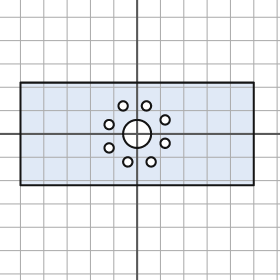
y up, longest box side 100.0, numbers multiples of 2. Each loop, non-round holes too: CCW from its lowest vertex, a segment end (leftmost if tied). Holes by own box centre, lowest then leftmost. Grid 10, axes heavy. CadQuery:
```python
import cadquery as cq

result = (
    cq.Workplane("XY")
    .moveTo(-50.0, -22.0)
    .lineTo(50.0, -22.0)
    .lineTo(50.0, 22.0)
    .lineTo(-50.0, 22.0)
    .close()
    .moveTo(-4.0, -12.0)
    .circle(2.0)
    .moveTo(6.0, -12.0)
    .circle(2.0)
    .moveTo(-12.0, -6.0)
    .circle(2.0)
    .moveTo(12.0, -4.0)
    .circle(2.0)
    .moveTo(0.0, 0.0)
    .circle(6.0)
    .moveTo(-12.0, 4.0)
    .circle(2.0)
    .moveTo(12.0, 6.0)
    .circle(2.0)
    .moveTo(-6.0, 12.0)
    .circle(2.0)
    .moveTo(4.0, 12.0)
    .circle(2.0)
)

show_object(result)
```